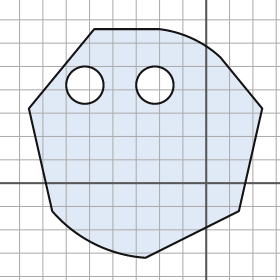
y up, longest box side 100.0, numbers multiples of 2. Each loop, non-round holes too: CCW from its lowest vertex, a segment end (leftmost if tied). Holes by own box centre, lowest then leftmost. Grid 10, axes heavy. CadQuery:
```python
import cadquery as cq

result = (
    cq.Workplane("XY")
    .moveTo(-26.0, -32.0)
    .lineTo(14.0, -12.0)
    .lineTo(24.0, 32.0)
    .lineTo(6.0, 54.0)
    .threePointArc((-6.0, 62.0), (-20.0, 66.0))
    .lineTo(-48.0, 66.0)
    .lineTo(-76.0, 32.0)
    .lineTo(-66.0, -12.0)
    .threePointArc((-48.0, -26.0), (-26.0, -32.0))
    .close()
    .moveTo(-52.0, 42.0)
    .circle(8.0)
    .moveTo(-22.0, 42.0)
    .circle(8.0)
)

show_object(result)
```